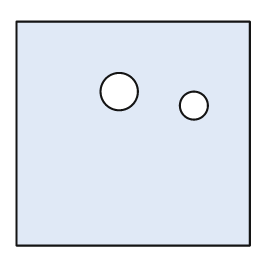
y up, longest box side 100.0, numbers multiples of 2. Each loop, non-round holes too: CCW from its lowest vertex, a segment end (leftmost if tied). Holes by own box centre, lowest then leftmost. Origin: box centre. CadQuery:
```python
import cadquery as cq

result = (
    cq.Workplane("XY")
    .moveTo(-50.0, -48.0)
    .lineTo(50.0, -48.0)
    .lineTo(50.0, 48.0)
    .lineTo(-50.0, 48.0)
    .close()
    .moveTo(26.0, 12.0)
    .circle(6.0)
    .moveTo(-6.0, 18.0)
    .circle(8.0)
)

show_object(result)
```